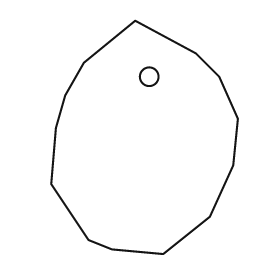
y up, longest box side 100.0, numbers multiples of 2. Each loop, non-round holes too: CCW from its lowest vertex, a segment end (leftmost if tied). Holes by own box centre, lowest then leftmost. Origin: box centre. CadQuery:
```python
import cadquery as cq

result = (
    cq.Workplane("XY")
    .moveTo(8.0, -50.0)
    .lineTo(28.0, -34.0)
    .lineTo(38.0, -12.0)
    .lineTo(40.0, 8.0)
    .lineTo(32.0, 26.0)
    .lineTo(22.0, 36.0)
    .lineTo(-4.0, 50.0)
    .lineTo(-26.0, 32.0)
    .lineTo(-34.0, 18.0)
    .lineTo(-38.0, 4.0)
    .lineTo(-40.0, -20.0)
    .lineTo(-24.0, -44.0)
    .lineTo(-14.0, -48.0)
    .close()
    .moveTo(2.0, 26.0)
    .circle(4.0)
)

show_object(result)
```